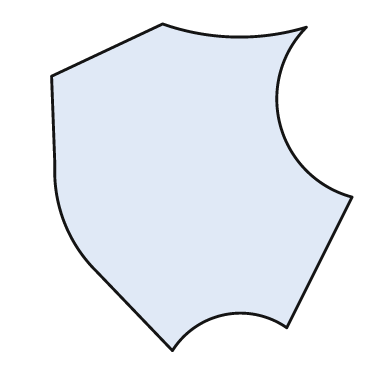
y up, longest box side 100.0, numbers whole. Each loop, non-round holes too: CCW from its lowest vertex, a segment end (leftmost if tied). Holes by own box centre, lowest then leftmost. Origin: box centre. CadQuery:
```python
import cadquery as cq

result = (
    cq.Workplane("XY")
    .moveTo(-9.0, -50.0)
    .threePointArc((7.0, -39.0), (26.0, -43.0))
    .lineTo(46.0, -3.0)
    .threePointArc((24.0, 19.0), (32.0, 49.0))
    .threePointArc((10.0, 46.0), (-12.0, 50.0))
    .lineTo(-46.0, 34.0)
    .lineTo(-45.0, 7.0)
    .threePointArc((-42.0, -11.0), (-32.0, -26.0))
    .close()
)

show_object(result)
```